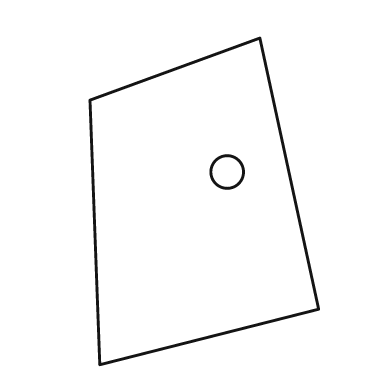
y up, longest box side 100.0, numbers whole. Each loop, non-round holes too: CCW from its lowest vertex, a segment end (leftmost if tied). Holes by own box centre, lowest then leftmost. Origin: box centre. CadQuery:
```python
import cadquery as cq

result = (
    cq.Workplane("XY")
    .moveTo(-32.0, -50.0)
    .lineTo(35.0, -33.0)
    .lineTo(17.0, 50.0)
    .lineTo(-35.0, 31.0)
    .close()
    .moveTo(7.0, 9.0)
    .circle(5.0)
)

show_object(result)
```